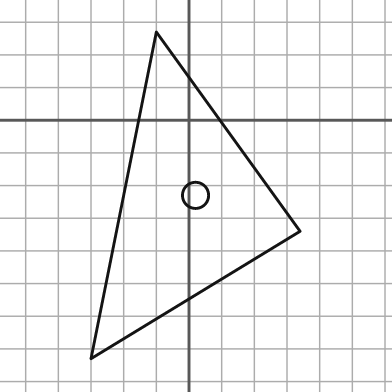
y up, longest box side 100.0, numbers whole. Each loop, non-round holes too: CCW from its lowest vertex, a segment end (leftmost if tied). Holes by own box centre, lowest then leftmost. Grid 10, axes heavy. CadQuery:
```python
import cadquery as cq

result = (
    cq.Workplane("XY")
    .moveTo(-30.0, -73.0)
    .lineTo(34.0, -34.0)
    .lineTo(-10.0, 27.0)
    .close()
    .moveTo(2.0, -23.0)
    .circle(4.0)
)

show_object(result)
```